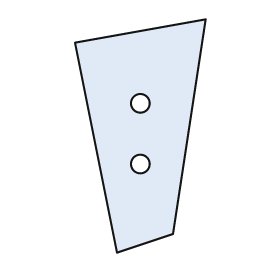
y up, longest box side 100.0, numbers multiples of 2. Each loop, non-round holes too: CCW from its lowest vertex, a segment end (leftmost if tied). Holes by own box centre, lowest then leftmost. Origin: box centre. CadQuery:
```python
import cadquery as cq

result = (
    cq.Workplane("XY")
    .moveTo(-10.0, -50.0)
    .lineTo(14.0, -42.0)
    .lineTo(28.0, 50.0)
    .lineTo(-28.0, 40.0)
    .close()
    .moveTo(0.0, -12.0)
    .circle(4.0)
    .moveTo(0.0, 14.0)
    .circle(4.0)
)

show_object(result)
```